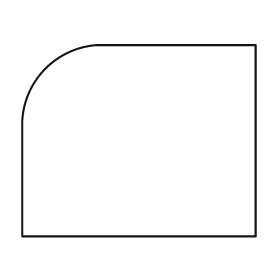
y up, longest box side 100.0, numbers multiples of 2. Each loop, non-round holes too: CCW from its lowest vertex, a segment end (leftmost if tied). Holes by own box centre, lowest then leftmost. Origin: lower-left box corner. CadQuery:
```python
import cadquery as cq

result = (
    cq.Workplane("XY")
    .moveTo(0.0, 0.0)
    .lineTo(100.0, 0.0)
    .lineTo(100.0, 82.0)
    .lineTo(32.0, 82.0)
    .threePointArc((10.0, 72.0), (0.0, 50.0))
    .close()
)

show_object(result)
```